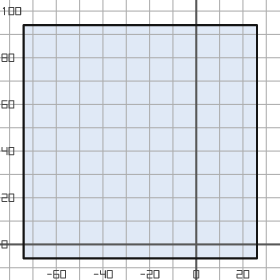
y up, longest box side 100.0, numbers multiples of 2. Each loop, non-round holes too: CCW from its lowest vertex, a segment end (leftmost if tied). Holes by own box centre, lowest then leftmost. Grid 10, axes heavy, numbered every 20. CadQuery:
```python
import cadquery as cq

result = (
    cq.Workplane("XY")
    .moveTo(-74.0, -6.0)
    .lineTo(26.0, -6.0)
    .lineTo(26.0, 94.0)
    .lineTo(-74.0, 94.0)
    .close()
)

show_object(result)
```